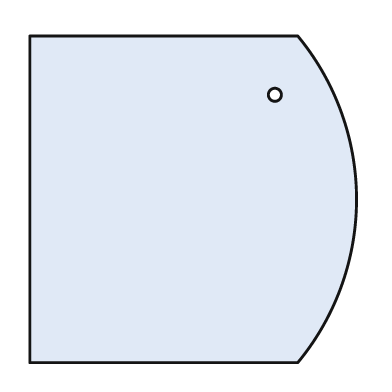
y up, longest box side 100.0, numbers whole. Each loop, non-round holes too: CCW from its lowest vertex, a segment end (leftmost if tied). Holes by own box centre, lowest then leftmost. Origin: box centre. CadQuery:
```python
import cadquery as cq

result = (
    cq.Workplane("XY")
    .moveTo(-50.0, -50.0)
    .lineTo(32.0, -50.0)
    .threePointArc((50.0, 0.0), (32.0, 50.0))
    .lineTo(-50.0, 50.0)
    .close()
    .moveTo(25.0, 32.0)
    .circle(2.0)
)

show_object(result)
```